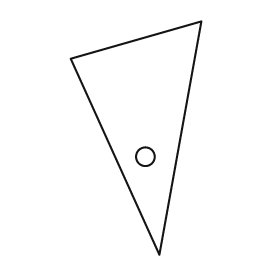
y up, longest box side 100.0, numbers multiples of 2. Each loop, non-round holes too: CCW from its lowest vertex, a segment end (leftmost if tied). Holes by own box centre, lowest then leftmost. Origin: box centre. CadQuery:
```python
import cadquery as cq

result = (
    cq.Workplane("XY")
    .moveTo(10.0, -50.0)
    .lineTo(28.0, 50.0)
    .lineTo(-28.0, 34.0)
    .close()
    .moveTo(4.0, -8.0)
    .circle(4.0)
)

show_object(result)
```